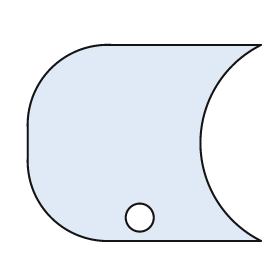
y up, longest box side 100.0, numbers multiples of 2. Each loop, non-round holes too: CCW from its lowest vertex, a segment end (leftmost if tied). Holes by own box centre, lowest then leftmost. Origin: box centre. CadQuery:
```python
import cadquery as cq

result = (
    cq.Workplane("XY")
    .moveTo(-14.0, -42.0)
    .lineTo(50.0, -42.0)
    .threePointArc((24.0, 0.0), (50.0, 42.0))
    .lineTo(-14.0, 42.0)
    .threePointArc((-40.0, 32.0), (-50.0, 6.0))
    .lineTo(-50.0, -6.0)
    .threePointArc((-40.0, -32.0), (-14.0, -42.0))
    .close()
    .moveTo(-2.0, -32.0)
    .circle(6.0)
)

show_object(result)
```